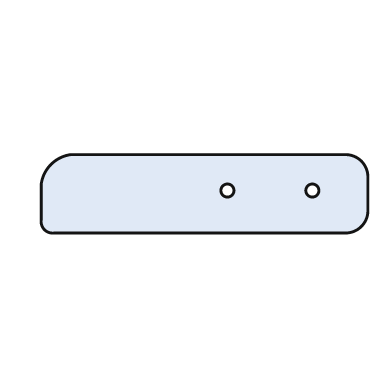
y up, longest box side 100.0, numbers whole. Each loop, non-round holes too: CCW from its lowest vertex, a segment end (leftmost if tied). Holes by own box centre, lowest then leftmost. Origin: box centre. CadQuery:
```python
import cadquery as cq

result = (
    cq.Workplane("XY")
    .moveTo(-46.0, -12.0)
    .lineTo(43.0, -12.0)
    .threePointArc((48.0, -10.0), (50.0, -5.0))
    .lineTo(50.0, 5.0)
    .threePointArc((48.0, 10.0), (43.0, 12.0))
    .lineTo(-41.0, 12.0)
    .threePointArc((-47.0, 9.0), (-50.0, 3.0))
    .lineTo(-50.0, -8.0)
    .threePointArc((-49.0, -11.0), (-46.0, -12.0))
    .close()
    .moveTo(7.0, 1.0)
    .circle(2.0)
    .moveTo(33.0, 1.0)
    .circle(2.0)
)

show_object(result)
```